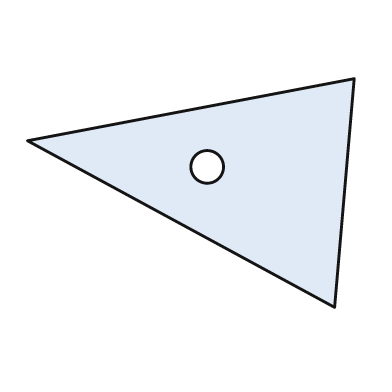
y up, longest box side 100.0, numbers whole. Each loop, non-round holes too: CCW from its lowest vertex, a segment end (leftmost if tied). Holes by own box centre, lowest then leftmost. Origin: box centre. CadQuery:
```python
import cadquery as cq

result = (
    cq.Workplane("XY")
    .moveTo(44.0, -35.0)
    .lineTo(50.0, 35.0)
    .lineTo(-50.0, 16.0)
    .close()
    .moveTo(5.0, 8.0)
    .circle(5.0)
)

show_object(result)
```